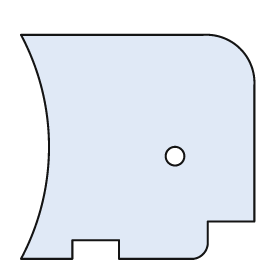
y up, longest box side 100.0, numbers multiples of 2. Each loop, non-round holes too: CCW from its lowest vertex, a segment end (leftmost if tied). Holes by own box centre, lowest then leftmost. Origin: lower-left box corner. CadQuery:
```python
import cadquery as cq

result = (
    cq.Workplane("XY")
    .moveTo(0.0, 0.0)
    .lineTo(22.0, 0.0)
    .lineTo(22.0, 8.0)
    .lineTo(42.0, 8.0)
    .lineTo(42.0, 0.0)
    .lineTo(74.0, 0.0)
    .threePointArc((78.0, 2.0), (80.0, 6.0))
    .lineTo(80.0, 16.0)
    .lineTo(100.0, 16.0)
    .lineTo(100.0, 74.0)
    .threePointArc((94.0, 90.0), (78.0, 96.0))
    .lineTo(0.0, 96.0)
    .threePointArc((12.0, 48.0), (0.0, 0.0))
    .close()
    .moveTo(66.0, 44.0)
    .circle(4.0)
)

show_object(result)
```